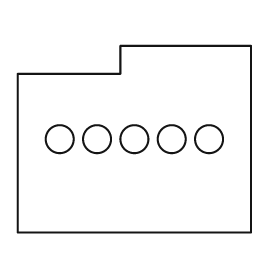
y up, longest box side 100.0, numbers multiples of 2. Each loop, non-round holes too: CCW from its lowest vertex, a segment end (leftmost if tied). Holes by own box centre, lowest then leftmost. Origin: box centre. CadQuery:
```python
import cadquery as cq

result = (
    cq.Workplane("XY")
    .moveTo(-50.0, -40.0)
    .lineTo(50.0, -40.0)
    .lineTo(50.0, 40.0)
    .lineTo(-6.0, 40.0)
    .lineTo(-6.0, 28.0)
    .lineTo(-50.0, 28.0)
    .close()
    .moveTo(-32.0, 0.0)
    .circle(6.0)
    .moveTo(-16.0, 0.0)
    .circle(6.0)
    .moveTo(0.0, 0.0)
    .circle(6.0)
    .moveTo(16.0, 0.0)
    .circle(6.0)
    .moveTo(32.0, 0.0)
    .circle(6.0)
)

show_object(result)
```